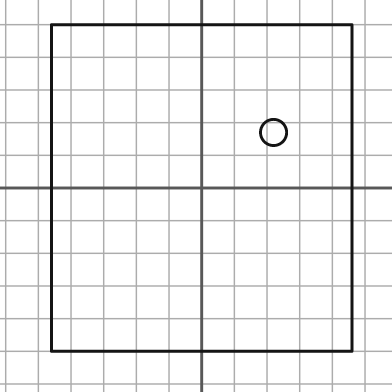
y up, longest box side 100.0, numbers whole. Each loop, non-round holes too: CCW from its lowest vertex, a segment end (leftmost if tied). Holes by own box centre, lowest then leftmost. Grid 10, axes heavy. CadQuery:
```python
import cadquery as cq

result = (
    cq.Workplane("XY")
    .moveTo(-46.0, -50.0)
    .lineTo(46.0, -50.0)
    .lineTo(46.0, 50.0)
    .lineTo(-46.0, 50.0)
    .close()
    .moveTo(22.0, 17.0)
    .circle(4.0)
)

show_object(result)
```